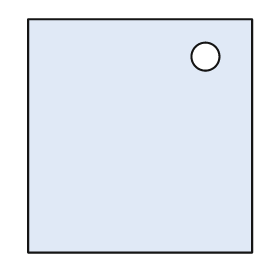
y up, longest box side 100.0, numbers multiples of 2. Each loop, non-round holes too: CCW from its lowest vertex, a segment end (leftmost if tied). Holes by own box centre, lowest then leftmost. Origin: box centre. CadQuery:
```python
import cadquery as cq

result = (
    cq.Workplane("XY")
    .moveTo(-48.0, -50.0)
    .lineTo(48.0, -50.0)
    .lineTo(48.0, 50.0)
    .lineTo(-48.0, 50.0)
    .close()
    .moveTo(28.0, 34.0)
    .circle(6.0)
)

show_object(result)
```